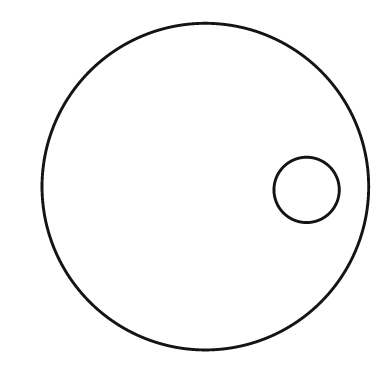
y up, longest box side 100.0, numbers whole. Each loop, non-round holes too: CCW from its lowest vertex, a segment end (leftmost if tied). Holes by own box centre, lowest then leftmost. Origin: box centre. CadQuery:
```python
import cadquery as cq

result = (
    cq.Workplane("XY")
    .moveTo(0.0, 0.0)
    .circle(50.0)
    .moveTo(31.0, -1.0)
    .circle(10.0)
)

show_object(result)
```